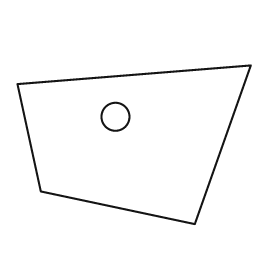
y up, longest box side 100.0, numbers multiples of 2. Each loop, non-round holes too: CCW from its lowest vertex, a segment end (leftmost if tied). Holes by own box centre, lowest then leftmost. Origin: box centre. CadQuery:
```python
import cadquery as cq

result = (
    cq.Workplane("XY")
    .moveTo(26.0, -34.0)
    .lineTo(50.0, 34.0)
    .lineTo(-50.0, 26.0)
    .lineTo(-40.0, -20.0)
    .close()
    .moveTo(-8.0, 12.0)
    .circle(6.0)
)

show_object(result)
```